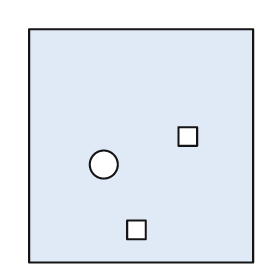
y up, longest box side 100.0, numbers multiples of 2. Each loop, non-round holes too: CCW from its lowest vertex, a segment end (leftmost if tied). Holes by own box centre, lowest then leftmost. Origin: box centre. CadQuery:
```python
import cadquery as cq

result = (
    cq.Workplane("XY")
    .moveTo(-48.0, -50.0)
    .lineTo(48.0, -50.0)
    .lineTo(48.0, 50.0)
    .lineTo(-48.0, 50.0)
    .close()
    .moveTo(-6.0, -40.0)
    .lineTo(2.0, -40.0)
    .lineTo(2.0, -32.0)
    .lineTo(-6.0, -32.0)
    .close()
    .moveTo(-16.0, -8.0)
    .circle(6.0)
    .moveTo(16.0, 0.0)
    .lineTo(24.0, 0.0)
    .lineTo(24.0, 8.0)
    .lineTo(16.0, 8.0)
    .close()
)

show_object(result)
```